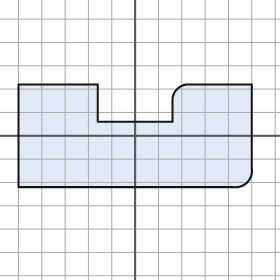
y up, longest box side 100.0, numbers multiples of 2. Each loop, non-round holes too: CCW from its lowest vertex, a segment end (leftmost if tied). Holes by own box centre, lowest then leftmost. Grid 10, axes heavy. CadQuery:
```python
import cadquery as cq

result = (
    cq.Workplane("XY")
    .moveTo(-50.0, -22.0)
    .lineTo(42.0, -22.0)
    .threePointArc((48.0, -20.0), (50.0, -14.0))
    .lineTo(50.0, 22.0)
    .lineTo(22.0, 22.0)
    .threePointArc((18.0, 20.0), (16.0, 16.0))
    .lineTo(16.0, 6.0)
    .lineTo(-16.0, 6.0)
    .lineTo(-16.0, 22.0)
    .lineTo(-50.0, 22.0)
    .close()
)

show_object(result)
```